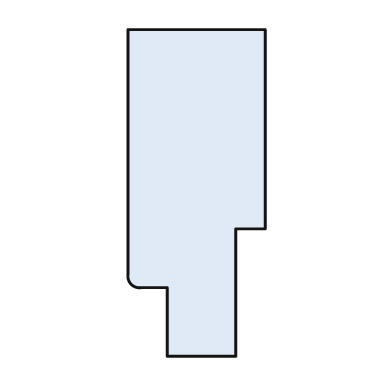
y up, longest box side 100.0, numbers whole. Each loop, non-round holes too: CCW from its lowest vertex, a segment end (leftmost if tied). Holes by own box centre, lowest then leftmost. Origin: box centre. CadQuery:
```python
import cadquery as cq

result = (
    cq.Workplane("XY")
    .moveTo(-9.0, -50.0)
    .lineTo(12.0, -50.0)
    .lineTo(12.0, -11.0)
    .lineTo(21.0, -11.0)
    .lineTo(21.0, 50.0)
    .lineTo(-21.0, 50.0)
    .lineTo(-21.0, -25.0)
    .threePointArc((-20.0, -28.0), (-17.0, -29.0))
    .lineTo(-9.0, -29.0)
    .close()
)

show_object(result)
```